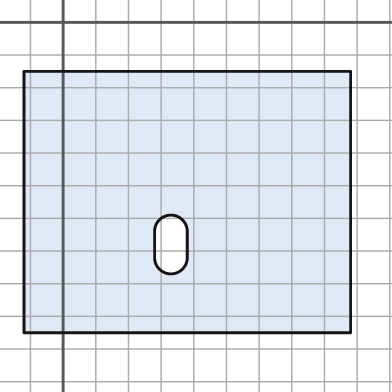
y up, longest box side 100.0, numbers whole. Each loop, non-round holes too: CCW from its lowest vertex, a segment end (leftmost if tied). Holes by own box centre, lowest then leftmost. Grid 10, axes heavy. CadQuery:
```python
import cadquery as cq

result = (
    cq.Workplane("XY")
    .moveTo(-12.0, -95.0)
    .lineTo(88.0, -95.0)
    .lineTo(88.0, -15.0)
    .lineTo(-12.0, -15.0)
    .close()
    .moveTo(28.0, -72.0)
    .threePointArc((33.0, -77.0), (38.0, -72.0))
    .lineTo(38.0, -64.0)
    .threePointArc((33.0, -59.0), (28.0, -64.0))
    .close()
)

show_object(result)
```